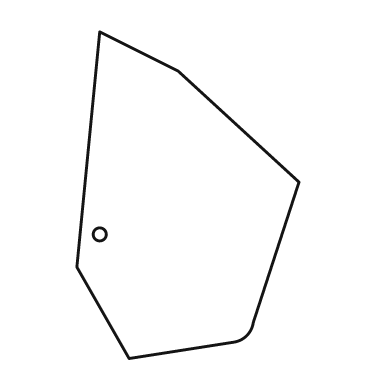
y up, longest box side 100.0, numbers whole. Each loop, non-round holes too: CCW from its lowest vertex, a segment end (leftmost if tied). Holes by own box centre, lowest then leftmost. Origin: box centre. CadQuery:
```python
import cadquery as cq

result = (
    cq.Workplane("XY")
    .moveTo(-18.0, -50.0)
    .lineTo(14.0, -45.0)
    .threePointArc((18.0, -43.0), (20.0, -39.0))
    .lineTo(34.0, 4.0)
    .lineTo(-3.0, 38.0)
    .lineTo(-27.0, 50.0)
    .lineTo(-34.0, -22.0)
    .close()
    .moveTo(-27.0, -12.0)
    .circle(2.0)
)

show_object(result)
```